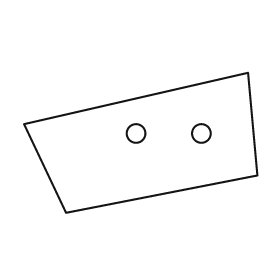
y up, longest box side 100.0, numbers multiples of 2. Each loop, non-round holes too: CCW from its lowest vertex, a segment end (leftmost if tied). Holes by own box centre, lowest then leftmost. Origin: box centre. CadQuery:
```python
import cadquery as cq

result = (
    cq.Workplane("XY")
    .moveTo(-32.0, -30.0)
    .lineTo(50.0, -14.0)
    .lineTo(46.0, 30.0)
    .lineTo(-50.0, 8.0)
    .close()
    .moveTo(-2.0, 4.0)
    .circle(4.0)
    .moveTo(26.0, 4.0)
    .circle(4.0)
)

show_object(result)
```